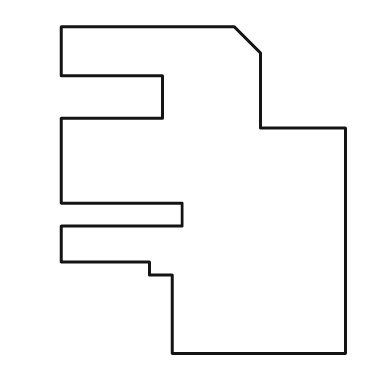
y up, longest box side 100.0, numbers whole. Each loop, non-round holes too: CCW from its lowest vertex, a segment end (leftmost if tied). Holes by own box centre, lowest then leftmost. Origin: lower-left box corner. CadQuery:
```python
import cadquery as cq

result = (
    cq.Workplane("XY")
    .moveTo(34.0, 0.0)
    .lineTo(87.0, 0.0)
    .lineTo(87.0, 69.0)
    .lineTo(61.0, 69.0)
    .lineTo(61.0, 92.0)
    .lineTo(53.0, 100.0)
    .lineTo(0.0, 100.0)
    .lineTo(0.0, 85.0)
    .lineTo(31.0, 85.0)
    .lineTo(31.0, 72.0)
    .lineTo(0.0, 72.0)
    .lineTo(0.0, 46.0)
    .lineTo(37.0, 46.0)
    .lineTo(37.0, 39.0)
    .lineTo(0.0, 39.0)
    .lineTo(0.0, 28.0)
    .lineTo(27.0, 28.0)
    .lineTo(27.0, 24.0)
    .lineTo(34.0, 24.0)
    .close()
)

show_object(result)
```